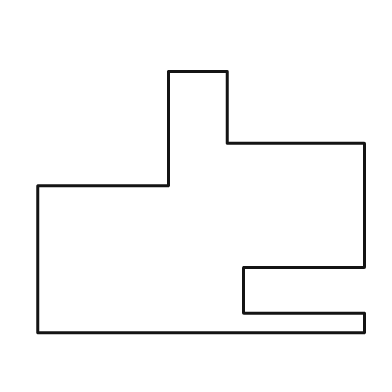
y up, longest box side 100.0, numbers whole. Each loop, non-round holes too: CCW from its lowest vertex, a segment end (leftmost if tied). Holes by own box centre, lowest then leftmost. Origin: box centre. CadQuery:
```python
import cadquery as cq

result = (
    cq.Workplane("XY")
    .moveTo(-50.0, -40.0)
    .lineTo(50.0, -40.0)
    .lineTo(50.0, -34.0)
    .lineTo(13.0, -34.0)
    .lineTo(13.0, -20.0)
    .lineTo(50.0, -20.0)
    .lineTo(50.0, 18.0)
    .lineTo(8.0, 18.0)
    .lineTo(8.0, 40.0)
    .lineTo(-10.0, 40.0)
    .lineTo(-10.0, 5.0)
    .lineTo(-50.0, 5.0)
    .close()
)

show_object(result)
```